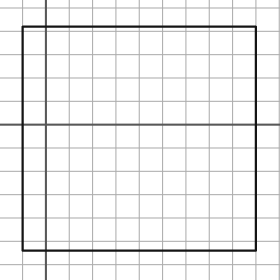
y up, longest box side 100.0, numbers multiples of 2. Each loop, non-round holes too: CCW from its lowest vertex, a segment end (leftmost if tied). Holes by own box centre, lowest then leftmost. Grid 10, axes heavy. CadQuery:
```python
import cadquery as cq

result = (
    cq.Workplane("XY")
    .moveTo(-10.0, -54.0)
    .lineTo(90.0, -54.0)
    .lineTo(90.0, 42.0)
    .lineTo(-10.0, 42.0)
    .close()
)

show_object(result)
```